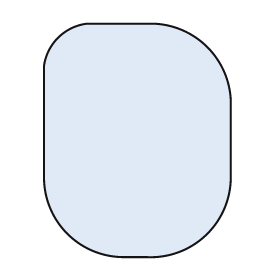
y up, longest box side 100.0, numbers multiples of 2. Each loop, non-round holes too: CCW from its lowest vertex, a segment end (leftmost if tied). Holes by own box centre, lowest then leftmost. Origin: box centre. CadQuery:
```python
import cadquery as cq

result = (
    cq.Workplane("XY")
    .moveTo(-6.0, -50.0)
    .lineTo(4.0, -50.0)
    .threePointArc((30.0, -40.0), (40.0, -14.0))
    .lineTo(40.0, 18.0)
    .threePointArc((30.0, 40.0), (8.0, 50.0))
    .lineTo(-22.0, 50.0)
    .threePointArc((-34.0, 44.0), (-40.0, 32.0))
    .lineTo(-40.0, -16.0)
    .threePointArc((-30.0, -40.0), (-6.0, -50.0))
    .close()
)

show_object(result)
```